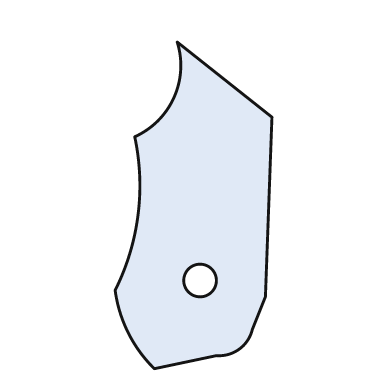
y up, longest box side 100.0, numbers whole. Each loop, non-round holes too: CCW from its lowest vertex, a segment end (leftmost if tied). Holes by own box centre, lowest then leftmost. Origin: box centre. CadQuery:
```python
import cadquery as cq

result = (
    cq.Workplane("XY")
    .moveTo(-12.0, -50.0)
    .lineTo(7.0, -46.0)
    .threePointArc((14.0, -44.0), (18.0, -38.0))
    .lineTo(22.0, -28.0)
    .lineTo(24.0, 27.0)
    .lineTo(-5.0, 50.0)
    .threePointArc((-6.0, 33.0), (-18.0, 21.0))
    .threePointArc((-17.0, -3.0), (-24.0, -26.0))
    .threePointArc((-20.0, -39.0), (-12.0, -50.0))
    .close()
    .moveTo(2.0, -23.0)
    .circle(5.0)
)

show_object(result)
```